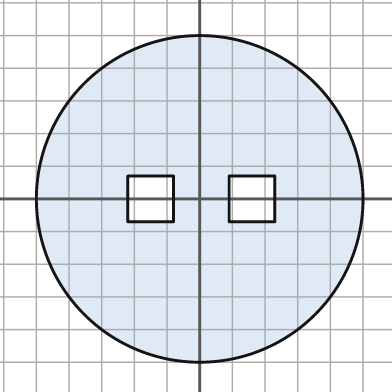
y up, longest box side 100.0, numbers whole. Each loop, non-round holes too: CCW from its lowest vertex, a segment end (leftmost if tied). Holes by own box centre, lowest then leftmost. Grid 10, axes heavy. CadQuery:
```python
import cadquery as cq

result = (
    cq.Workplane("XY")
    .moveTo(0.0, 0.0)
    .circle(50.0)
    .moveTo(-22.0, -7.0)
    .lineTo(-8.0, -7.0)
    .lineTo(-8.0, 7.0)
    .lineTo(-22.0, 7.0)
    .close()
    .moveTo(9.0, -7.0)
    .lineTo(23.0, -7.0)
    .lineTo(23.0, 7.0)
    .lineTo(9.0, 7.0)
    .close()
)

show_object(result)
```